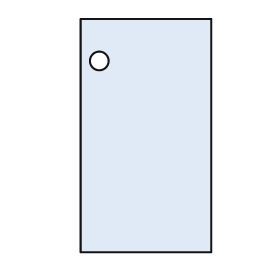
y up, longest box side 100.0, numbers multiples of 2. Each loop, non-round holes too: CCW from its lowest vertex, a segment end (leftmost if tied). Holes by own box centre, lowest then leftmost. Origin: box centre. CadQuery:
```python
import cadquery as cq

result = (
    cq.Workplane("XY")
    .moveTo(-28.0, -50.0)
    .lineTo(28.0, -50.0)
    .lineTo(28.0, 50.0)
    .lineTo(-28.0, 50.0)
    .close()
    .moveTo(-20.0, 32.0)
    .circle(4.0)
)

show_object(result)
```